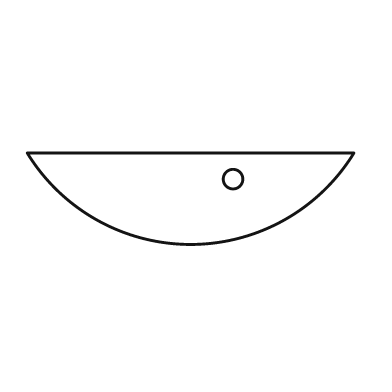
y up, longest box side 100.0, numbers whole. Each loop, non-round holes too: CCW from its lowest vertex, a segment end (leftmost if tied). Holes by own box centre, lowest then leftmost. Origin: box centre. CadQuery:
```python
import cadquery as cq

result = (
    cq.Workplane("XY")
    .moveTo(-50.0, 14.0)
    .threePointArc((0.0, -14.0), (50.0, 14.0))
    .close()
    .moveTo(13.0, 6.0)
    .circle(3.0)
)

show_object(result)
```